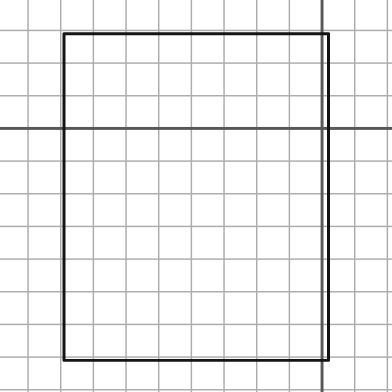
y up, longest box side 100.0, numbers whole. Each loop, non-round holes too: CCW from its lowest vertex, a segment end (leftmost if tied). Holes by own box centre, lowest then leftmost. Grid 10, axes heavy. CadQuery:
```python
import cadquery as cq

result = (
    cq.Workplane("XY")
    .moveTo(-79.0, -71.0)
    .lineTo(2.0, -71.0)
    .lineTo(2.0, 29.0)
    .lineTo(-79.0, 29.0)
    .close()
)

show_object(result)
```